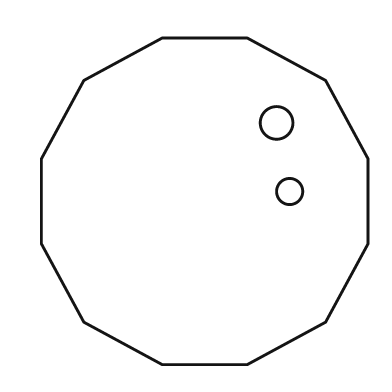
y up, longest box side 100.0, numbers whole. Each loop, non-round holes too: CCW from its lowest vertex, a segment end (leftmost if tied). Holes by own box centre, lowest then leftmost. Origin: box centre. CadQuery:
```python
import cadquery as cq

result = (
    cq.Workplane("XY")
    .moveTo(-13.0, -50.0)
    .lineTo(13.0, -50.0)
    .lineTo(37.0, -37.0)
    .lineTo(50.0, -13.0)
    .lineTo(50.0, 13.0)
    .lineTo(37.0, 37.0)
    .lineTo(13.0, 50.0)
    .lineTo(-13.0, 50.0)
    .lineTo(-37.0, 37.0)
    .lineTo(-50.0, 13.0)
    .lineTo(-50.0, -13.0)
    .lineTo(-37.0, -37.0)
    .close()
    .moveTo(26.0, 3.0)
    .circle(4.0)
    .moveTo(22.0, 24.0)
    .circle(5.0)
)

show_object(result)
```